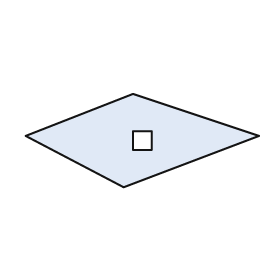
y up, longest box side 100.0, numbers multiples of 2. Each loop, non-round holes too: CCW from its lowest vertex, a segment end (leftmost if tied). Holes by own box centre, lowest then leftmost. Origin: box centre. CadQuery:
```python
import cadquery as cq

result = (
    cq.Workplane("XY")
    .moveTo(-8.0, -20.0)
    .lineTo(50.0, 2.0)
    .lineTo(-4.0, 20.0)
    .lineTo(-50.0, 2.0)
    .close()
    .moveTo(-4.0, -4.0)
    .lineTo(4.0, -4.0)
    .lineTo(4.0, 4.0)
    .lineTo(-4.0, 4.0)
    .close()
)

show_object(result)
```